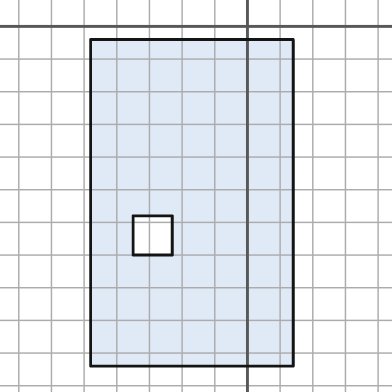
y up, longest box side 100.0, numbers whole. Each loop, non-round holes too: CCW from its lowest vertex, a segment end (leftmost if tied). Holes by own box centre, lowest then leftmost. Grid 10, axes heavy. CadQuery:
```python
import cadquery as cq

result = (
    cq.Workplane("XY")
    .moveTo(-48.0, -104.0)
    .lineTo(14.0, -104.0)
    .lineTo(14.0, -4.0)
    .lineTo(-48.0, -4.0)
    .close()
    .moveTo(-35.0, -70.0)
    .lineTo(-23.0, -70.0)
    .lineTo(-23.0, -58.0)
    .lineTo(-35.0, -58.0)
    .close()
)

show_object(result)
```